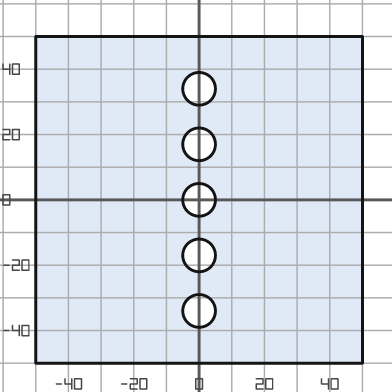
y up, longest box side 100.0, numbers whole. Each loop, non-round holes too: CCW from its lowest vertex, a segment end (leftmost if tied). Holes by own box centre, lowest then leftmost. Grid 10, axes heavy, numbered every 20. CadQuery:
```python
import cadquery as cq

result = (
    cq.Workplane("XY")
    .moveTo(-50.0, -50.0)
    .lineTo(50.0, -50.0)
    .lineTo(50.0, 50.0)
    .lineTo(-50.0, 50.0)
    .close()
    .moveTo(0.0, -34.0)
    .circle(5.0)
    .moveTo(0.0, -17.0)
    .circle(5.0)
    .moveTo(0.0, 0.0)
    .circle(5.0)
    .moveTo(0.0, 17.0)
    .circle(5.0)
    .moveTo(0.0, 34.0)
    .circle(5.0)
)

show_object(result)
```